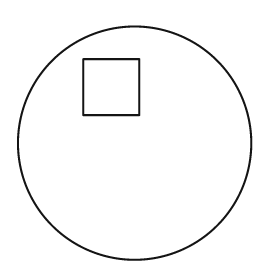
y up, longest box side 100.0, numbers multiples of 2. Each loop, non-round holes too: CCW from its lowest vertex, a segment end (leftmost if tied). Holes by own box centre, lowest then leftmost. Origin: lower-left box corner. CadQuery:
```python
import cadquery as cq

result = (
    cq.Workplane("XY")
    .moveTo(50.0, 50.0)
    .circle(50.0)
    .moveTo(28.0, 62.0)
    .lineTo(52.0, 62.0)
    .lineTo(52.0, 86.0)
    .lineTo(28.0, 86.0)
    .close()
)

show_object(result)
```